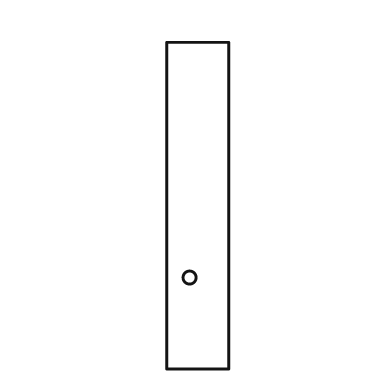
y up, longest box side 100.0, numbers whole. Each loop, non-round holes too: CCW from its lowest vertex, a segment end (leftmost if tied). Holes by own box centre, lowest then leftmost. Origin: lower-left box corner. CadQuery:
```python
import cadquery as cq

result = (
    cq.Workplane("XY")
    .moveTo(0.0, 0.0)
    .lineTo(19.0, 0.0)
    .lineTo(19.0, 100.0)
    .lineTo(0.0, 100.0)
    .close()
    .moveTo(7.0, 28.0)
    .circle(2.0)
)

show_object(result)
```